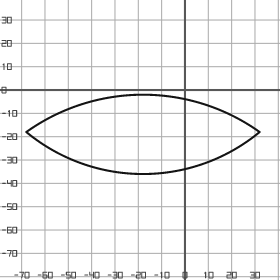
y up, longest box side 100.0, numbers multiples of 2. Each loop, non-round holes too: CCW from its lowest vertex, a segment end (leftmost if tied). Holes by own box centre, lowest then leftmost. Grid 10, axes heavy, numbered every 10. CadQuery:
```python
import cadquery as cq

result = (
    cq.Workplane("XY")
    .moveTo(-68.0, -18.0)
    .threePointArc((-18.0, -36.0), (32.0, -18.0))
    .threePointArc((-18.0, -2.0), (-68.0, -18.0))
    .close()
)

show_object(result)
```